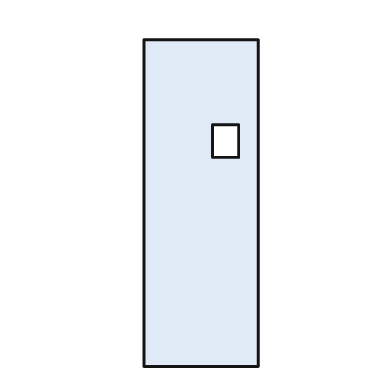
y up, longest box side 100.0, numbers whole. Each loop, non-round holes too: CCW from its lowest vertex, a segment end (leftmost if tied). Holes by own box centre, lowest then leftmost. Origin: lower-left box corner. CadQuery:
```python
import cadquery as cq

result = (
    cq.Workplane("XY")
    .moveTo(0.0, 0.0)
    .lineTo(35.0, 0.0)
    .lineTo(35.0, 100.0)
    .lineTo(0.0, 100.0)
    .close()
    .moveTo(21.0, 64.0)
    .lineTo(29.0, 64.0)
    .lineTo(29.0, 74.0)
    .lineTo(21.0, 74.0)
    .close()
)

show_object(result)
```